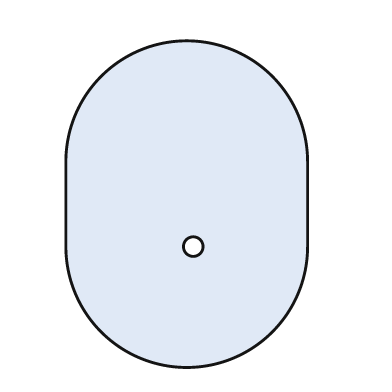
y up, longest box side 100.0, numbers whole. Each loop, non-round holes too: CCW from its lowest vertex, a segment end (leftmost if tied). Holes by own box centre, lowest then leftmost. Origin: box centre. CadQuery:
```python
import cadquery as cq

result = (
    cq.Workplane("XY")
    .moveTo(-37.0, -13.0)
    .threePointArc((0.0, -50.0), (37.0, -13.0))
    .lineTo(37.0, 13.0)
    .threePointArc((0.0, 50.0), (-37.0, 13.0))
    .close()
    .moveTo(2.0, -13.0)
    .circle(3.0)
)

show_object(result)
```